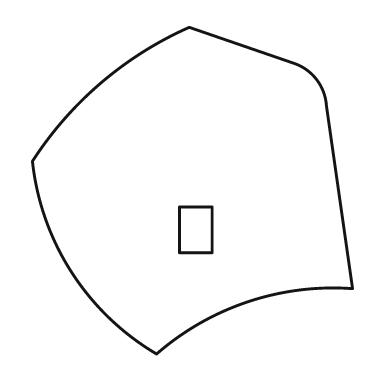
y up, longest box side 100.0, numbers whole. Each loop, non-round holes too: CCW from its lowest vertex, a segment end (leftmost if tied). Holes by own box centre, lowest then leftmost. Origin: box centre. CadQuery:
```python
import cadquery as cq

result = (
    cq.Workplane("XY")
    .moveTo(-11.0, -50.0)
    .threePointArc((17.0, -34.0), (49.0, -30.0))
    .lineTo(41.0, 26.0)
    .threePointArc((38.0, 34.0), (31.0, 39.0))
    .lineTo(-1.0, 50.0)
    .threePointArc((-28.0, 33.0), (-49.0, 9.0))
    .threePointArc((-37.0, -25.0), (-11.0, -50.0))
    .close()
    .moveTo(-4.0, -19.0)
    .lineTo(6.0, -19.0)
    .lineTo(6.0, -5.0)
    .lineTo(-4.0, -5.0)
    .close()
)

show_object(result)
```